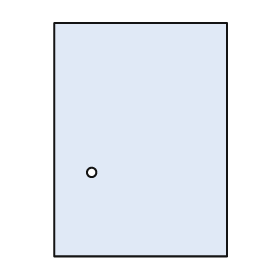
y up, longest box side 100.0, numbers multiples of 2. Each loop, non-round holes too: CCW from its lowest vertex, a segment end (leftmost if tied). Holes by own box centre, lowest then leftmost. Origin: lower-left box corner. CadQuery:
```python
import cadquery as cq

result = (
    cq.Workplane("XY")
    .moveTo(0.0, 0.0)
    .lineTo(74.0, 0.0)
    .lineTo(74.0, 100.0)
    .lineTo(0.0, 100.0)
    .close()
    .moveTo(16.0, 36.0)
    .circle(2.0)
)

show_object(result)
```